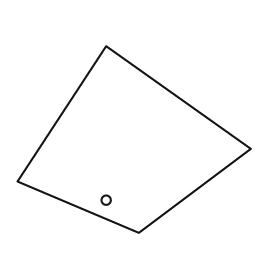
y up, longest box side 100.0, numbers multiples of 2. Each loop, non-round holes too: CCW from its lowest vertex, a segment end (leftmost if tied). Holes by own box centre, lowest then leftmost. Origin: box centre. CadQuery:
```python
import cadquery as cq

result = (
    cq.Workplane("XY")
    .moveTo(2.0, -40.0)
    .lineTo(50.0, -4.0)
    .lineTo(-12.0, 40.0)
    .lineTo(-50.0, -18.0)
    .close()
    .moveTo(-12.0, -26.0)
    .circle(2.0)
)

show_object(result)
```